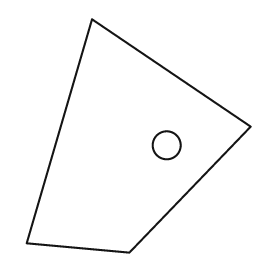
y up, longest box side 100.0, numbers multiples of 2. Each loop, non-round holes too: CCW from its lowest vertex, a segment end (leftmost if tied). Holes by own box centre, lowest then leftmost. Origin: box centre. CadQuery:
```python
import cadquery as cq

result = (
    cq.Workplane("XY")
    .moveTo(-4.0, -50.0)
    .lineTo(48.0, 4.0)
    .lineTo(-20.0, 50.0)
    .lineTo(-48.0, -46.0)
    .close()
    .moveTo(12.0, -4.0)
    .circle(6.0)
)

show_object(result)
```